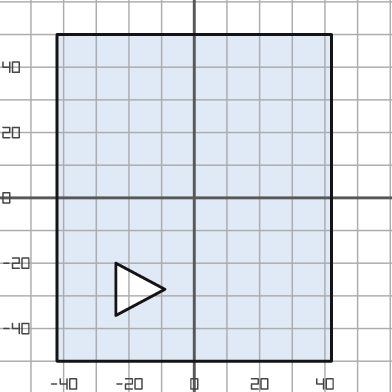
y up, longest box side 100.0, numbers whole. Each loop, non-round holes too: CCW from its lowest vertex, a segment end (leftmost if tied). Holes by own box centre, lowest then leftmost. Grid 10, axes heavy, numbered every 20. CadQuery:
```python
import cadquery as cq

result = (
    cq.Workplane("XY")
    .moveTo(-42.0, -50.0)
    .lineTo(42.0, -50.0)
    .lineTo(42.0, 50.0)
    .lineTo(-42.0, 50.0)
    .close()
    .moveTo(-24.0, -36.0)
    .lineTo(-9.0, -28.0)
    .lineTo(-24.0, -20.0)
    .close()
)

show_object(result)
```